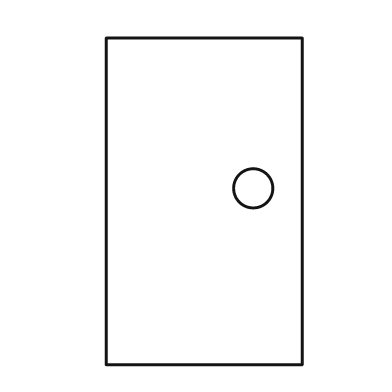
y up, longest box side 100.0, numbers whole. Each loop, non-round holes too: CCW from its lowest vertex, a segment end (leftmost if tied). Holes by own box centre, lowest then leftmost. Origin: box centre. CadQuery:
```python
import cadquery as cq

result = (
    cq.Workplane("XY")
    .moveTo(-30.0, -50.0)
    .lineTo(30.0, -50.0)
    .lineTo(30.0, 50.0)
    .lineTo(-30.0, 50.0)
    .close()
    .moveTo(15.0, 4.0)
    .circle(6.0)
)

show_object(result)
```